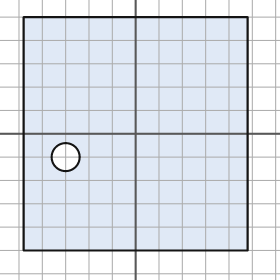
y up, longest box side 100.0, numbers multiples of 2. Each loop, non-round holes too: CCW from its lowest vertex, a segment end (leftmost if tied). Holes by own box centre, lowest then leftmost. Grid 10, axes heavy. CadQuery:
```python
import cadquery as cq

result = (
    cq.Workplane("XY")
    .moveTo(-48.0, -50.0)
    .lineTo(48.0, -50.0)
    .lineTo(48.0, 50.0)
    .lineTo(-48.0, 50.0)
    .close()
    .moveTo(-30.0, -10.0)
    .circle(6.0)
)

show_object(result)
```